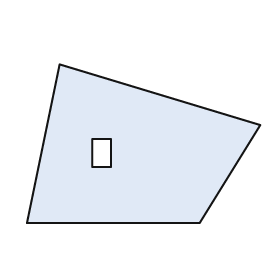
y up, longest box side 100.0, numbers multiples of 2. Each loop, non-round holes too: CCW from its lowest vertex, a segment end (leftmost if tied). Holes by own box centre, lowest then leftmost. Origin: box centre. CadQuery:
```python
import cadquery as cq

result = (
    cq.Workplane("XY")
    .moveTo(-50.0, -34.0)
    .lineTo(24.0, -34.0)
    .lineTo(50.0, 8.0)
    .lineTo(-36.0, 34.0)
    .close()
    .moveTo(-22.0, -10.0)
    .lineTo(-14.0, -10.0)
    .lineTo(-14.0, 2.0)
    .lineTo(-22.0, 2.0)
    .close()
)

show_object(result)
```